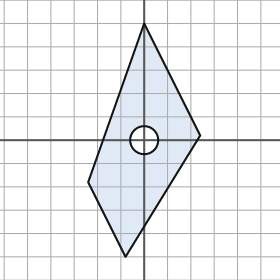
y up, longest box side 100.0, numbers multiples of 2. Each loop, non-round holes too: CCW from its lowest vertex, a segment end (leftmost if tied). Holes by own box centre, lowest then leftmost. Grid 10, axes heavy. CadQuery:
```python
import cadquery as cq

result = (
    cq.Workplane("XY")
    .moveTo(-8.0, -50.0)
    .lineTo(24.0, 2.0)
    .lineTo(0.0, 50.0)
    .lineTo(-24.0, -18.0)
    .close()
    .moveTo(0.0, 0.0)
    .circle(6.0)
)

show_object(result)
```